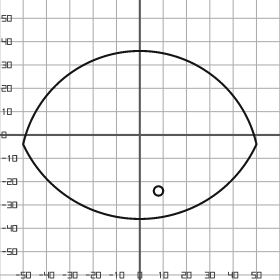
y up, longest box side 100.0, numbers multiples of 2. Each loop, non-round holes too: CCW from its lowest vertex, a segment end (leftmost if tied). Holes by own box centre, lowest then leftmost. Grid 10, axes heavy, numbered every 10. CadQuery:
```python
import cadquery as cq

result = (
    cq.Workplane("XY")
    .moveTo(-50.0, -4.0)
    .threePointArc((0.0, -36.0), (50.0, -4.0))
    .threePointArc((0.0, 36.0), (-50.0, -4.0))
    .close()
    .moveTo(8.0, -24.0)
    .circle(2.0)
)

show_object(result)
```